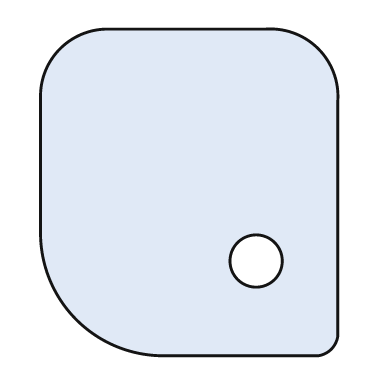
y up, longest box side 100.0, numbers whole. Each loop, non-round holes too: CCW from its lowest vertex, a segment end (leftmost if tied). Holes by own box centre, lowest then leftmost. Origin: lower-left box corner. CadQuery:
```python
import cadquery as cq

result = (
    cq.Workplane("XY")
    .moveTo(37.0, 0.0)
    .lineTo(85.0, 0.0)
    .threePointArc((89.0, 2.0), (91.0, 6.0))
    .lineTo(91.0, 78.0)
    .threePointArc((85.0, 94.0), (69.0, 100.0))
    .lineTo(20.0, 100.0)
    .threePointArc((6.0, 94.0), (0.0, 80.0))
    .lineTo(0.0, 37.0)
    .threePointArc((11.0, 11.0), (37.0, 0.0))
    .close()
    .moveTo(66.0, 29.0)
    .circle(8.0)
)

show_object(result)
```